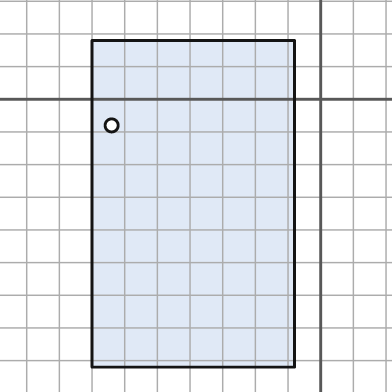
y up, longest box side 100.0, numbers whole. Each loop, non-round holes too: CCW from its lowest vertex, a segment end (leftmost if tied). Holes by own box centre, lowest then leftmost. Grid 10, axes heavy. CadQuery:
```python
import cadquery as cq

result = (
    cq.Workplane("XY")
    .moveTo(-70.0, -82.0)
    .lineTo(-8.0, -82.0)
    .lineTo(-8.0, 18.0)
    .lineTo(-70.0, 18.0)
    .close()
    .moveTo(-64.0, -8.0)
    .circle(2.0)
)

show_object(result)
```